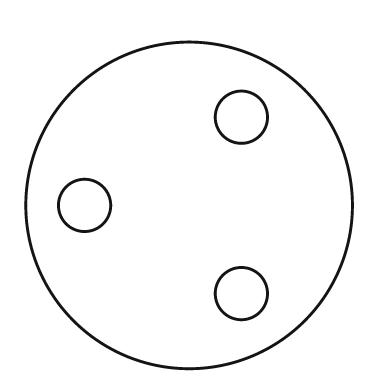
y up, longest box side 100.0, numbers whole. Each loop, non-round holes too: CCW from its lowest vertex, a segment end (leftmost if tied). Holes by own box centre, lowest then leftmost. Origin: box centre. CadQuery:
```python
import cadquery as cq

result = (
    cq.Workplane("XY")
    .moveTo(0.0, 0.0)
    .circle(50.0)
    .moveTo(16.0, -27.0)
    .circle(8.0)
    .moveTo(-32.0, 0.0)
    .circle(8.0)
    .moveTo(16.0, 27.0)
    .circle(8.0)
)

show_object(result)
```